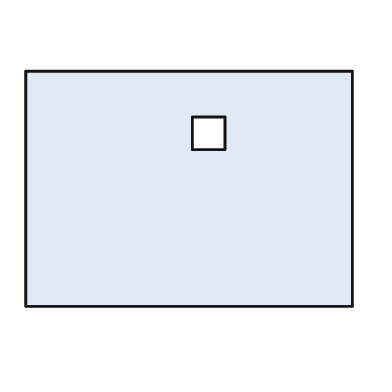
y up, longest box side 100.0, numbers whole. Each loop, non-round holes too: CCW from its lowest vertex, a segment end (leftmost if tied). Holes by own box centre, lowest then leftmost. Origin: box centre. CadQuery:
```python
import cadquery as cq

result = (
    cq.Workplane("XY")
    .moveTo(-50.0, -36.0)
    .lineTo(50.0, -36.0)
    .lineTo(50.0, 36.0)
    .lineTo(-50.0, 36.0)
    .close()
    .moveTo(1.0, 12.0)
    .lineTo(11.0, 12.0)
    .lineTo(11.0, 22.0)
    .lineTo(1.0, 22.0)
    .close()
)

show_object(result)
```